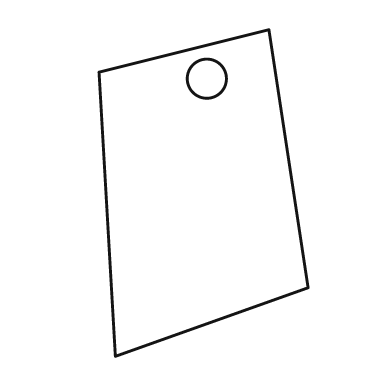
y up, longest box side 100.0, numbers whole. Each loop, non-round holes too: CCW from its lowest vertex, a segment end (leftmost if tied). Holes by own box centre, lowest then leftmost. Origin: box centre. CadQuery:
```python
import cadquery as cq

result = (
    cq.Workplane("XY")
    .moveTo(-27.0, -50.0)
    .lineTo(32.0, -29.0)
    .lineTo(20.0, 50.0)
    .lineTo(-32.0, 37.0)
    .close()
    .moveTo(1.0, 35.0)
    .circle(6.0)
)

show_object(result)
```